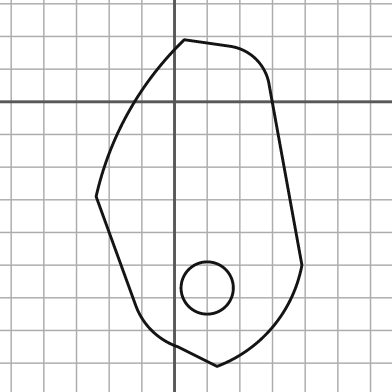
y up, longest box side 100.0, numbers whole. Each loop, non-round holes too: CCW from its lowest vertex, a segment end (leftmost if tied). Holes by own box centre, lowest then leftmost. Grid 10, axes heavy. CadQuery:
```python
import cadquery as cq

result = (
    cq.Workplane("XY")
    .moveTo(13.0, -81.0)
    .threePointArc((30.0, -69.0), (39.0, -50.0))
    .lineTo(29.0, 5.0)
    .threePointArc((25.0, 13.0), (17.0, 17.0))
    .lineTo(3.0, 19.0)
    .threePointArc((-14.0, -3.0), (-24.0, -29.0))
    .lineTo(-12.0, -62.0)
    .threePointArc((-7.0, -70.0), (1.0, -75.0))
    .close()
    .moveTo(10.0, -57.0)
    .circle(8.0)
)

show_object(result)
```